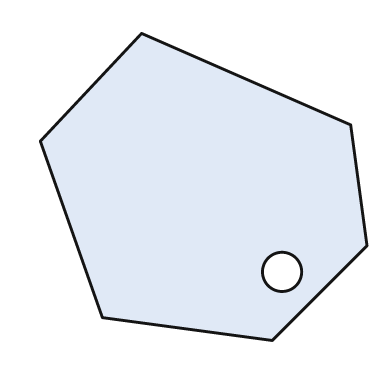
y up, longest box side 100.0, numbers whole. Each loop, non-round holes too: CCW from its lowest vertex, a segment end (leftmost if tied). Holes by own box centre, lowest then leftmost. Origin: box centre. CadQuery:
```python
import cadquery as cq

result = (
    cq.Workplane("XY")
    .moveTo(21.0, -47.0)
    .lineTo(50.0, -18.0)
    .lineTo(45.0, 19.0)
    .lineTo(-19.0, 47.0)
    .lineTo(-50.0, 14.0)
    .lineTo(-31.0, -40.0)
    .close()
    .moveTo(24.0, -26.0)
    .circle(6.0)
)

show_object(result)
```